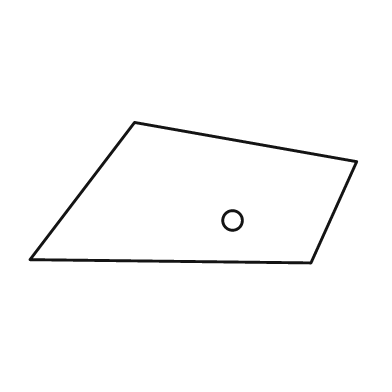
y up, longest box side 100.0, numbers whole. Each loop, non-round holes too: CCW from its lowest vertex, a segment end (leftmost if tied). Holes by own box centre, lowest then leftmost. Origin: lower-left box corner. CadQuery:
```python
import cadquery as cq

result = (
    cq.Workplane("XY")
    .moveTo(86.0, 0.0)
    .lineTo(100.0, 31.0)
    .lineTo(32.0, 43.0)
    .lineTo(0.0, 1.0)
    .close()
    .moveTo(62.0, 13.0)
    .circle(3.0)
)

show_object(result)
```